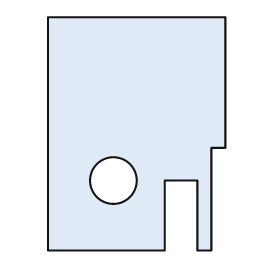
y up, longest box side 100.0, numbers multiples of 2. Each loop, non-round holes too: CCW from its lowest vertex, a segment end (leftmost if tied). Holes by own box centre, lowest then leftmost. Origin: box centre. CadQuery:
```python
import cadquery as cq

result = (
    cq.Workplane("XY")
    .moveTo(-38.0, -50.0)
    .lineTo(12.0, -50.0)
    .lineTo(12.0, -20.0)
    .lineTo(26.0, -20.0)
    .lineTo(26.0, -50.0)
    .lineTo(32.0, -50.0)
    .lineTo(32.0, -6.0)
    .lineTo(38.0, -6.0)
    .lineTo(38.0, 50.0)
    .lineTo(-38.0, 50.0)
    .close()
    .moveTo(-10.0, -20.0)
    .circle(10.0)
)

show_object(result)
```